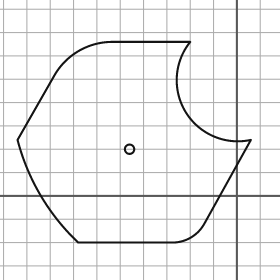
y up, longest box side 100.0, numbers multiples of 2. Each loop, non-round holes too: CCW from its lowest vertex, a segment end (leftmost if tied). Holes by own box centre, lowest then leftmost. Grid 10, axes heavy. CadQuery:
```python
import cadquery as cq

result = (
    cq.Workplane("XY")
    .moveTo(-68.0, -20.0)
    .lineTo(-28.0, -20.0)
    .threePointArc((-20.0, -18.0), (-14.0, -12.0))
    .lineTo(6.0, 24.0)
    .threePointArc((-22.0, 36.0), (-20.0, 66.0))
    .lineTo(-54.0, 66.0)
    .threePointArc((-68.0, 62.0), (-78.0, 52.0))
    .lineTo(-94.0, 24.0)
    .threePointArc((-84.0, 0.0), (-68.0, -20.0))
    .close()
    .moveTo(-46.0, 20.0)
    .circle(2.0)
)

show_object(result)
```